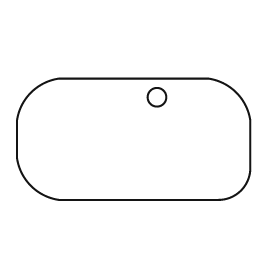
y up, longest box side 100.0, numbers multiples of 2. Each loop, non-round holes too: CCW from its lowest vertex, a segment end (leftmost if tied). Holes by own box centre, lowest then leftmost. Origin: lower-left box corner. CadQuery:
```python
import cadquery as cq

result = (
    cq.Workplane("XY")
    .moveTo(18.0, 0.0)
    .lineTo(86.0, 0.0)
    .threePointArc((96.0, 4.0), (100.0, 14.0))
    .lineTo(100.0, 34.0)
    .threePointArc((94.0, 46.0), (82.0, 52.0))
    .lineTo(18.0, 52.0)
    .threePointArc((6.0, 46.0), (0.0, 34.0))
    .lineTo(0.0, 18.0)
    .threePointArc((6.0, 6.0), (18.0, 0.0))
    .close()
    .moveTo(60.0, 44.0)
    .circle(4.0)
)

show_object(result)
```